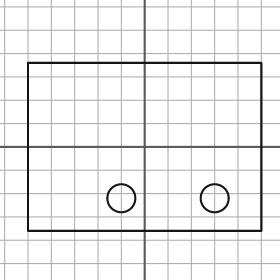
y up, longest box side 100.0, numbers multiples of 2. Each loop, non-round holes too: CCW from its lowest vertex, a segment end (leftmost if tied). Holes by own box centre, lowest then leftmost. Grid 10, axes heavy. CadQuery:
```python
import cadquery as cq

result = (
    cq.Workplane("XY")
    .moveTo(-50.0, -36.0)
    .lineTo(50.0, -36.0)
    .lineTo(50.0, 36.0)
    .lineTo(-50.0, 36.0)
    .close()
    .moveTo(-10.0, -22.0)
    .circle(6.0)
    .moveTo(30.0, -22.0)
    .circle(6.0)
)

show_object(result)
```